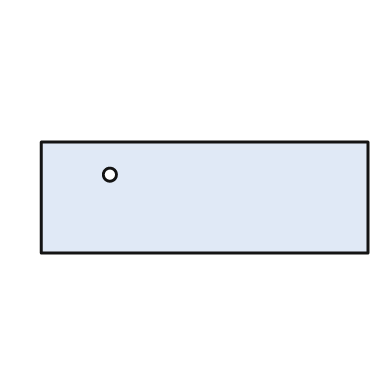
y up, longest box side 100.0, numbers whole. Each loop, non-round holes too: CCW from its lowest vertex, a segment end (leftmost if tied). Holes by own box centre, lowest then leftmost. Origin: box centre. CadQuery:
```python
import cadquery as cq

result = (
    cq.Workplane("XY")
    .moveTo(-50.0, -17.0)
    .lineTo(50.0, -17.0)
    .lineTo(50.0, 17.0)
    .lineTo(-50.0, 17.0)
    .close()
    .moveTo(-29.0, 7.0)
    .circle(2.0)
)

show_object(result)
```